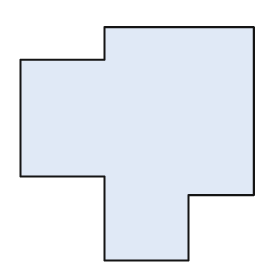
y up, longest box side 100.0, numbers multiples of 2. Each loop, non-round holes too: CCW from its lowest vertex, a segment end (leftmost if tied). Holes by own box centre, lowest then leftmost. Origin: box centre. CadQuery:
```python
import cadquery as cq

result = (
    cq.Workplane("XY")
    .moveTo(-14.0, -50.0)
    .lineTo(22.0, -50.0)
    .lineTo(22.0, -22.0)
    .lineTo(50.0, -22.0)
    .lineTo(50.0, 50.0)
    .lineTo(-14.0, 50.0)
    .lineTo(-14.0, 36.0)
    .lineTo(-50.0, 36.0)
    .lineTo(-50.0, -14.0)
    .lineTo(-14.0, -14.0)
    .close()
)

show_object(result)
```